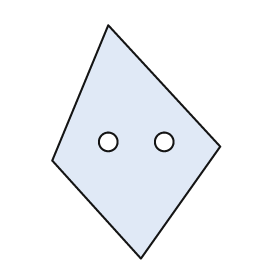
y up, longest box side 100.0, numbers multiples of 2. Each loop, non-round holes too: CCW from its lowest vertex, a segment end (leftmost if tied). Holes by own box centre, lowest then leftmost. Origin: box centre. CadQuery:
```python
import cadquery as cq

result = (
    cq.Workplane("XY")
    .moveTo(2.0, -50.0)
    .lineTo(36.0, -2.0)
    .lineTo(-12.0, 50.0)
    .lineTo(-36.0, -8.0)
    .close()
    .moveTo(-12.0, 0.0)
    .circle(4.0)
    .moveTo(12.0, 0.0)
    .circle(4.0)
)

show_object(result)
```